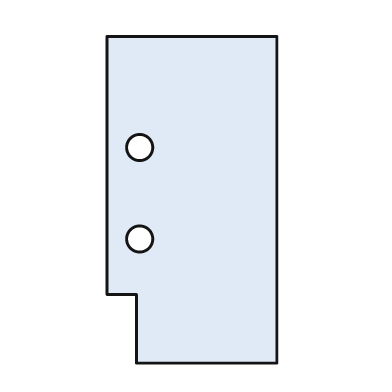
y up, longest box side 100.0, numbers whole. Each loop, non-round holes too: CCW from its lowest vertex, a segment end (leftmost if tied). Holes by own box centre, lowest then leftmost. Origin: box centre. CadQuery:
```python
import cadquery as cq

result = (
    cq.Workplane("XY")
    .moveTo(-17.0, -50.0)
    .lineTo(26.0, -50.0)
    .lineTo(26.0, 50.0)
    .lineTo(-26.0, 50.0)
    .lineTo(-26.0, -29.0)
    .lineTo(-17.0, -29.0)
    .close()
    .moveTo(-16.0, -12.0)
    .circle(4.0)
    .moveTo(-16.0, 16.0)
    .circle(4.0)
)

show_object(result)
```